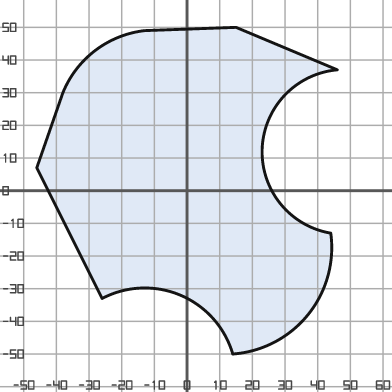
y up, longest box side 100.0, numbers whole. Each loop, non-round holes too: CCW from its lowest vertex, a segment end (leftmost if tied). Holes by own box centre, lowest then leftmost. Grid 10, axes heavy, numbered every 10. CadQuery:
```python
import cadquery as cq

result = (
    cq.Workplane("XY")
    .moveTo(14.0, -50.0)
    .threePointArc((37.0, -38.0), (44.0, -13.0))
    .threePointArc((23.0, 13.0), (46.0, 37.0))
    .lineTo(15.0, 50.0)
    .lineTo(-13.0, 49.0)
    .threePointArc((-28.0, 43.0), (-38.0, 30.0))
    .lineTo(-46.0, 7.0)
    .lineTo(-26.0, -33.0)
    .threePointArc((-2.0, -32.0), (14.0, -50.0))
    .close()
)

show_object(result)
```